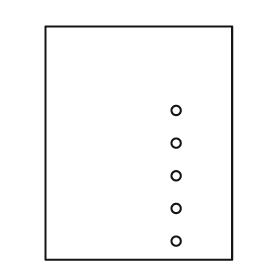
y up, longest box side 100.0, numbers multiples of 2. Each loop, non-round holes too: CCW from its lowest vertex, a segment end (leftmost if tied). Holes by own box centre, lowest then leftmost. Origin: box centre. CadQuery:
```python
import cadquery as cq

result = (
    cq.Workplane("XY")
    .moveTo(-40.0, -50.0)
    .lineTo(40.0, -50.0)
    .lineTo(40.0, 50.0)
    .lineTo(-40.0, 50.0)
    .close()
    .moveTo(16.0, -42.0)
    .circle(2.0)
    .moveTo(16.0, -28.0)
    .circle(2.0)
    .moveTo(16.0, -14.0)
    .circle(2.0)
    .moveTo(16.0, 0.0)
    .circle(2.0)
    .moveTo(16.0, 14.0)
    .circle(2.0)
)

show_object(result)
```